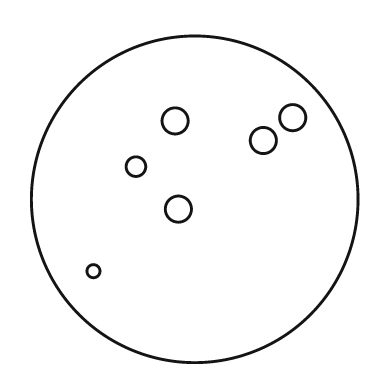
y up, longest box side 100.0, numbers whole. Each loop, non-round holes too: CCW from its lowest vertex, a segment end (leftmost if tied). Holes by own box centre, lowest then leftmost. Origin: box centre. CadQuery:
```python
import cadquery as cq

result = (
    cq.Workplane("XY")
    .moveTo(0.0, 0.0)
    .circle(50.0)
    .moveTo(-31.0, -22.0)
    .circle(2.0)
    .moveTo(-5.0, -3.0)
    .circle(4.0)
    .moveTo(-18.0, 10.0)
    .circle(3.0)
    .moveTo(21.0, 18.0)
    .circle(4.0)
    .moveTo(-6.0, 24.0)
    .circle(4.0)
    .moveTo(30.0, 25.0)
    .circle(4.0)
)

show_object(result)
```